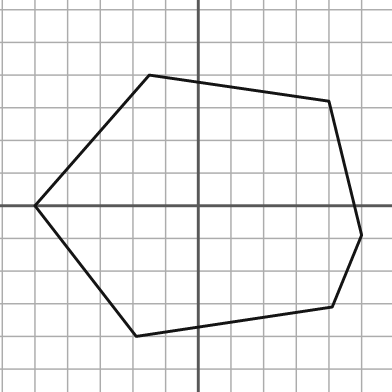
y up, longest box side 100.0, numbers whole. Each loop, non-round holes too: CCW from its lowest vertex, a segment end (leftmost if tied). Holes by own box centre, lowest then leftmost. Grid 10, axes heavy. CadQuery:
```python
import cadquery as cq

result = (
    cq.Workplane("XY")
    .moveTo(-19.0, -40.0)
    .lineTo(41.0, -31.0)
    .lineTo(50.0, -9.0)
    .lineTo(40.0, 32.0)
    .lineTo(-15.0, 40.0)
    .lineTo(-50.0, 0.0)
    .close()
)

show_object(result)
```